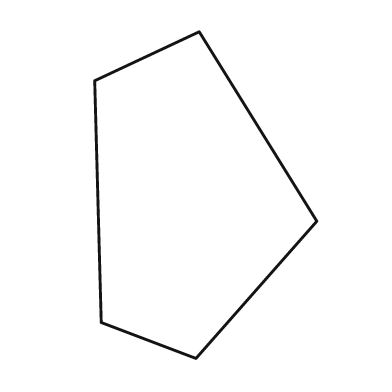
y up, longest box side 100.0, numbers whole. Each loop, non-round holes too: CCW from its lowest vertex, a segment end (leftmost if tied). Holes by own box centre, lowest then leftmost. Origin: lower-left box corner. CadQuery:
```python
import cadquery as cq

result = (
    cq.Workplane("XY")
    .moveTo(31.0, 0.0)
    .lineTo(68.0, 42.0)
    .lineTo(32.0, 100.0)
    .lineTo(0.0, 85.0)
    .lineTo(2.0, 11.0)
    .close()
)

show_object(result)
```